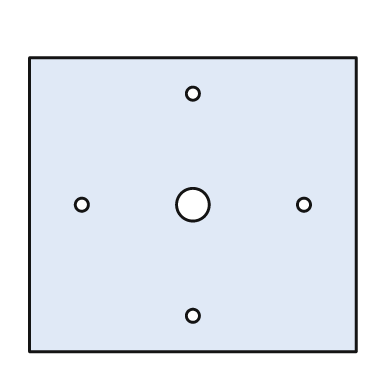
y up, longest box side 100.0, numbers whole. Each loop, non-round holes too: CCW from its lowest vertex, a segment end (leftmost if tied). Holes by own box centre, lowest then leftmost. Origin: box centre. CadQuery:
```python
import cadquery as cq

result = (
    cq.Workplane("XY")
    .moveTo(-50.0, -45.0)
    .lineTo(50.0, -45.0)
    .lineTo(50.0, 45.0)
    .lineTo(-50.0, 45.0)
    .close()
    .moveTo(0.0, -34.0)
    .circle(2.0)
    .moveTo(-34.0, 0.0)
    .circle(2.0)
    .moveTo(0.0, 0.0)
    .circle(5.0)
    .moveTo(34.0, 0.0)
    .circle(2.0)
    .moveTo(0.0, 34.0)
    .circle(2.0)
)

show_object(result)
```